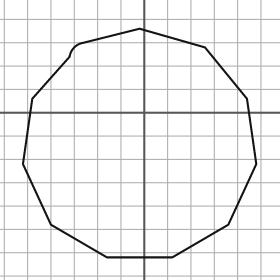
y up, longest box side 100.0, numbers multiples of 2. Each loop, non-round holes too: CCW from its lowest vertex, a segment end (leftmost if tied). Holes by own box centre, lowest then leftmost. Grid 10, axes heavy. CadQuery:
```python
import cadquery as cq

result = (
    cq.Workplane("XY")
    .moveTo(-16.0, -62.0)
    .lineTo(12.0, -62.0)
    .lineTo(36.0, -48.0)
    .lineTo(48.0, -22.0)
    .lineTo(44.0, 6.0)
    .lineTo(26.0, 28.0)
    .lineTo(-2.0, 36.0)
    .lineTo(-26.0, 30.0)
    .threePointArc((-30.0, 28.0), (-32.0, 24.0))
    .lineTo(-48.0, 6.0)
    .lineTo(-52.0, -22.0)
    .lineTo(-40.0, -48.0)
    .close()
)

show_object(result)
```